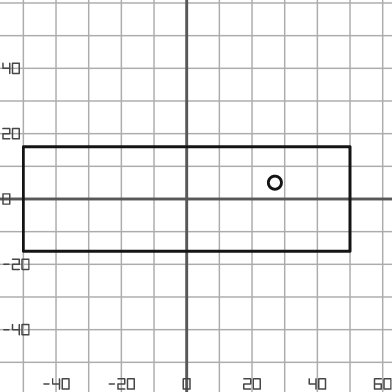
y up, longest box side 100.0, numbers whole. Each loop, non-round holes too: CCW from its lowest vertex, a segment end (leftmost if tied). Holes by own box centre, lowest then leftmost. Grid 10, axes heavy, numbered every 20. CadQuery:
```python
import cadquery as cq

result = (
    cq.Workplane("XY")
    .moveTo(-50.0, -16.0)
    .lineTo(50.0, -16.0)
    .lineTo(50.0, 16.0)
    .lineTo(-50.0, 16.0)
    .close()
    .moveTo(27.0, 5.0)
    .circle(2.0)
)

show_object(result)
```